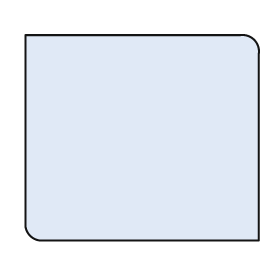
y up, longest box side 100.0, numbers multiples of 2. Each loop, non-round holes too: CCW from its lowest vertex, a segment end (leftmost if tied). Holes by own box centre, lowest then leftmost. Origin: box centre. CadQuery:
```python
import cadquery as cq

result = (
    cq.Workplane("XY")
    .moveTo(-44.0, -44.0)
    .lineTo(50.0, -44.0)
    .lineTo(50.0, 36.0)
    .threePointArc((48.0, 42.0), (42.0, 44.0))
    .lineTo(-50.0, 44.0)
    .lineTo(-50.0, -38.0)
    .threePointArc((-48.0, -42.0), (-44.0, -44.0))
    .close()
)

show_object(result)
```